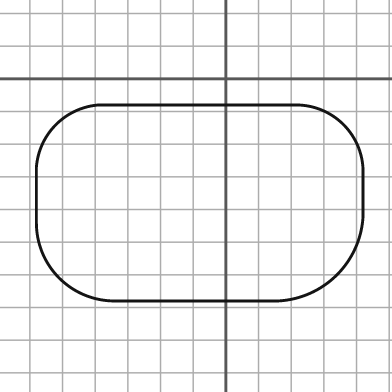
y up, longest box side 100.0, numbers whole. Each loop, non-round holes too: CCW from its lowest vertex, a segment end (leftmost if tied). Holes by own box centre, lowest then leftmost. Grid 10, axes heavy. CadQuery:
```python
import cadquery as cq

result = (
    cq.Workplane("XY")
    .moveTo(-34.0, -68.0)
    .lineTo(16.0, -68.0)
    .threePointArc((34.0, -60.0), (42.0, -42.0))
    .lineTo(42.0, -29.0)
    .threePointArc((36.0, -14.0), (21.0, -8.0))
    .lineTo(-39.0, -8.0)
    .threePointArc((-52.0, -14.0), (-58.0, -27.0))
    .lineTo(-58.0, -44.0)
    .threePointArc((-51.0, -61.0), (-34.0, -68.0))
    .close()
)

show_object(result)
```